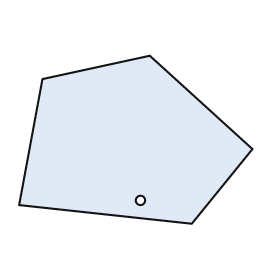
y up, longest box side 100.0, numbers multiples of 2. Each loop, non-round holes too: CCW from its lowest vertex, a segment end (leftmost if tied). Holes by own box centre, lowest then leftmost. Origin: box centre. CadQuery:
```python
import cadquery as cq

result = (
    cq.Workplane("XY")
    .moveTo(24.0, -36.0)
    .lineTo(50.0, -4.0)
    .lineTo(6.0, 36.0)
    .lineTo(-40.0, 26.0)
    .lineTo(-50.0, -28.0)
    .close()
    .moveTo(2.0, -26.0)
    .circle(2.0)
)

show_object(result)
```